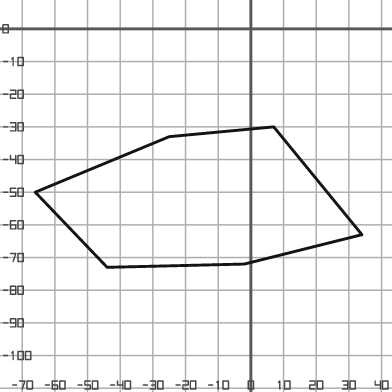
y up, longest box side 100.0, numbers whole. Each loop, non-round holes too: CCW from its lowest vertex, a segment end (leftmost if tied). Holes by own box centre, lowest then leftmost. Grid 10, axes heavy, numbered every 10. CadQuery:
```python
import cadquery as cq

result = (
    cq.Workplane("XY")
    .moveTo(-44.0, -73.0)
    .lineTo(-2.0, -72.0)
    .lineTo(34.0, -63.0)
    .lineTo(7.0, -30.0)
    .lineTo(-25.0, -33.0)
    .lineTo(-66.0, -50.0)
    .close()
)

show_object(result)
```